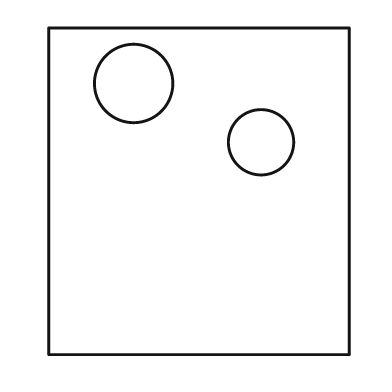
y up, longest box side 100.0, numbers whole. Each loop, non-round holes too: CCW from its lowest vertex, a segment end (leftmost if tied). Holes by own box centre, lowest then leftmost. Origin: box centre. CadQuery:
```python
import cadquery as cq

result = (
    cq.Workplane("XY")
    .moveTo(-46.0, -50.0)
    .lineTo(46.0, -50.0)
    .lineTo(46.0, 50.0)
    .lineTo(-46.0, 50.0)
    .close()
    .moveTo(19.0, 15.0)
    .circle(10.0)
    .moveTo(-20.0, 33.0)
    .circle(12.0)
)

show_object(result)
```